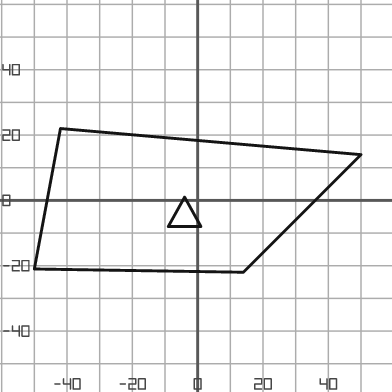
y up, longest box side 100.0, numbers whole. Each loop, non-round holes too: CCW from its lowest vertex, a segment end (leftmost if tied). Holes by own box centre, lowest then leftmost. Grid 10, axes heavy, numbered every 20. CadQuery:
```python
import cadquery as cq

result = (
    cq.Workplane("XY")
    .moveTo(14.0, -22.0)
    .lineTo(50.0, 14.0)
    .lineTo(-42.0, 22.0)
    .lineTo(-50.0, -21.0)
    .close()
    .moveTo(-9.0, -8.0)
    .lineTo(1.0, -8.0)
    .lineTo(-4.0, 1.0)
    .close()
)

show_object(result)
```